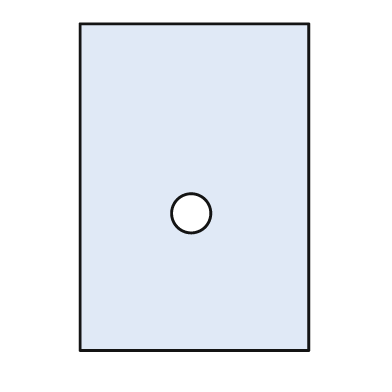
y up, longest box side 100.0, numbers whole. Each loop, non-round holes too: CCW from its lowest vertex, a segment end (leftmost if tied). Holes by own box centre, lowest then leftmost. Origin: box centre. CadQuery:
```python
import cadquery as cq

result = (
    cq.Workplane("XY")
    .moveTo(-35.0, -50.0)
    .lineTo(35.0, -50.0)
    .lineTo(35.0, 50.0)
    .lineTo(-35.0, 50.0)
    .close()
    .moveTo(-1.0, -8.0)
    .circle(6.0)
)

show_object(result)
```